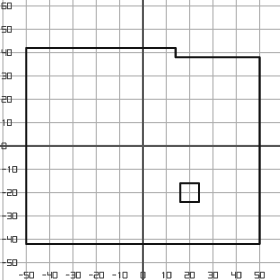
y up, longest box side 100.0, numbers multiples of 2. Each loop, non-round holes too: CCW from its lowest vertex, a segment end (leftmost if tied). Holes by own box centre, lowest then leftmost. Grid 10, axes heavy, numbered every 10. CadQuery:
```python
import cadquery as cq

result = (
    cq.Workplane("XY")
    .moveTo(-50.0, -42.0)
    .lineTo(50.0, -42.0)
    .lineTo(50.0, 38.0)
    .lineTo(14.0, 38.0)
    .lineTo(14.0, 42.0)
    .lineTo(-50.0, 42.0)
    .close()
    .moveTo(16.0, -24.0)
    .lineTo(24.0, -24.0)
    .lineTo(24.0, -16.0)
    .lineTo(16.0, -16.0)
    .close()
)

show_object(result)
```